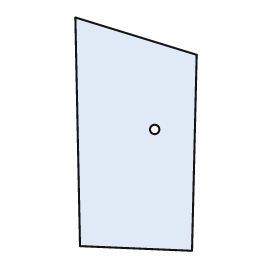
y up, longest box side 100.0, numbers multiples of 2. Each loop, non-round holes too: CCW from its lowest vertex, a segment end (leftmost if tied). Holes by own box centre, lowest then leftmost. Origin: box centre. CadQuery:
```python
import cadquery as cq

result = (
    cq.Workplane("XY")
    .moveTo(24.0, -50.0)
    .lineTo(26.0, 34.0)
    .lineTo(-26.0, 50.0)
    .lineTo(-24.0, -48.0)
    .close()
    .moveTo(8.0, 2.0)
    .circle(2.0)
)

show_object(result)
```